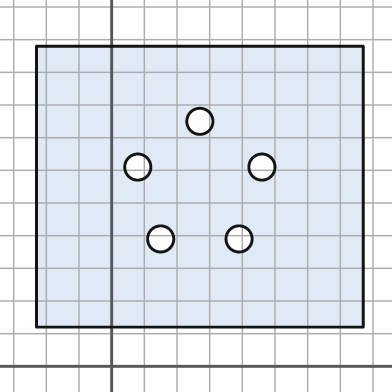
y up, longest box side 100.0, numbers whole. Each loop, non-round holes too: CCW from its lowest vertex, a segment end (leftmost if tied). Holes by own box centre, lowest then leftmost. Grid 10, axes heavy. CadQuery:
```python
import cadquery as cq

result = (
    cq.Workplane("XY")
    .moveTo(-23.0, 12.0)
    .lineTo(77.0, 12.0)
    .lineTo(77.0, 98.0)
    .lineTo(-23.0, 98.0)
    .close()
    .moveTo(15.0, 39.0)
    .circle(4.0)
    .moveTo(39.0, 39.0)
    .circle(4.0)
    .moveTo(8.0, 61.0)
    .circle(4.0)
    .moveTo(46.0, 61.0)
    .circle(4.0)
    .moveTo(27.0, 75.0)
    .circle(4.0)
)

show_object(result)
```